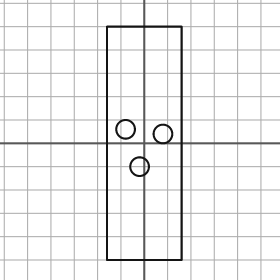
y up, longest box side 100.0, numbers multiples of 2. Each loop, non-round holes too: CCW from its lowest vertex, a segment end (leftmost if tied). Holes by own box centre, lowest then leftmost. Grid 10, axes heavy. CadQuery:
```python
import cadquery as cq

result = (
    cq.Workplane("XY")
    .moveTo(-16.0, -50.0)
    .lineTo(16.0, -50.0)
    .lineTo(16.0, 50.0)
    .lineTo(-16.0, 50.0)
    .close()
    .moveTo(-2.0, -10.0)
    .circle(4.0)
    .moveTo(8.0, 4.0)
    .circle(4.0)
    .moveTo(-8.0, 6.0)
    .circle(4.0)
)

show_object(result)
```